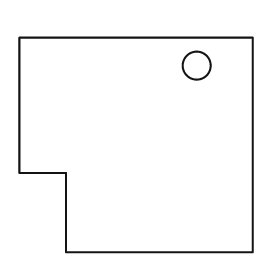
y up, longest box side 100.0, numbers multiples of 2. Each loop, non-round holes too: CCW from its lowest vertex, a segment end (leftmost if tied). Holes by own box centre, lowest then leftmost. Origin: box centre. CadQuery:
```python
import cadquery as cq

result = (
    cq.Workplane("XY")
    .moveTo(-30.0, -46.0)
    .lineTo(50.0, -46.0)
    .lineTo(50.0, 46.0)
    .lineTo(-50.0, 46.0)
    .lineTo(-50.0, -12.0)
    .lineTo(-30.0, -12.0)
    .close()
    .moveTo(26.0, 34.0)
    .circle(6.0)
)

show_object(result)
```